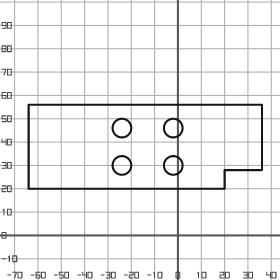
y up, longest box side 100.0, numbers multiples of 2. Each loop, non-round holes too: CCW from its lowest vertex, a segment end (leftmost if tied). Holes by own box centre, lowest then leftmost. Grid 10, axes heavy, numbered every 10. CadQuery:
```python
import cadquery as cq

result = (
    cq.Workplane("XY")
    .moveTo(-64.0, 20.0)
    .lineTo(20.0, 20.0)
    .lineTo(20.0, 28.0)
    .lineTo(36.0, 28.0)
    .lineTo(36.0, 56.0)
    .lineTo(-64.0, 56.0)
    .close()
    .moveTo(-24.0, 30.0)
    .circle(4.0)
    .moveTo(-2.0, 30.0)
    .circle(4.0)
    .moveTo(-24.0, 46.0)
    .circle(4.0)
    .moveTo(-2.0, 46.0)
    .circle(4.0)
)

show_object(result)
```